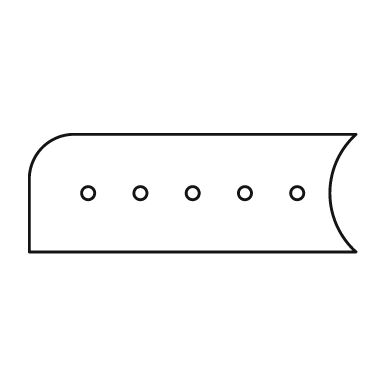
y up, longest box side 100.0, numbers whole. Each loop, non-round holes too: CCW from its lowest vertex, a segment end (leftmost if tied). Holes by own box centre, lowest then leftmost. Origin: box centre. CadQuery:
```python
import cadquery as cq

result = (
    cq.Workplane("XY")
    .moveTo(-50.0, -18.0)
    .lineTo(50.0, -18.0)
    .threePointArc((42.0, 0.0), (50.0, 18.0))
    .lineTo(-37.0, 18.0)
    .threePointArc((-46.0, 14.0), (-50.0, 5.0))
    .close()
    .moveTo(-32.0, 0.0)
    .circle(2.0)
    .moveTo(-16.0, 0.0)
    .circle(2.0)
    .moveTo(0.0, 0.0)
    .circle(2.0)
    .moveTo(16.0, 0.0)
    .circle(2.0)
    .moveTo(32.0, 0.0)
    .circle(2.0)
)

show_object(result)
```